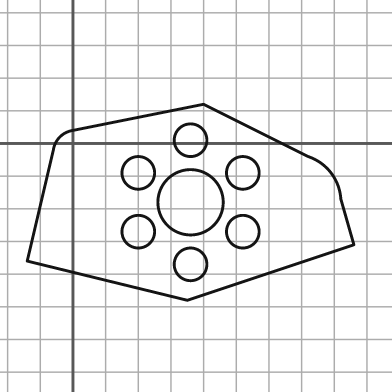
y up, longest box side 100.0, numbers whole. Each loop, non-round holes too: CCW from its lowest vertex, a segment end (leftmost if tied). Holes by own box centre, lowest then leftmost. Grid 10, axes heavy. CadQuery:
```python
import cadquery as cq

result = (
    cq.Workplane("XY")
    .moveTo(35.0, -48.0)
    .lineTo(86.0, -31.0)
    .lineTo(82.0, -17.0)
    .threePointArc((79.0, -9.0), (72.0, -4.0))
    .lineTo(40.0, 12.0)
    .lineTo(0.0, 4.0)
    .threePointArc((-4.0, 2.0), (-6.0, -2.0))
    .lineTo(-14.0, -36.0)
    .close()
    .moveTo(36.0, -37.0)
    .circle(5.0)
    .moveTo(20.0, -27.0)
    .circle(5.0)
    .moveTo(52.0, -27.0)
    .circle(5.0)
    .moveTo(36.0, -18.0)
    .circle(10.0)
    .moveTo(20.0, -9.0)
    .circle(5.0)
    .moveTo(52.0, -9.0)
    .circle(5.0)
    .moveTo(36.0, 1.0)
    .circle(5.0)
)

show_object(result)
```